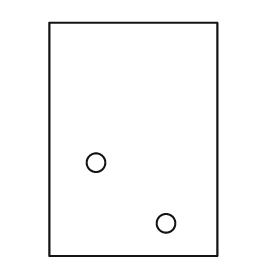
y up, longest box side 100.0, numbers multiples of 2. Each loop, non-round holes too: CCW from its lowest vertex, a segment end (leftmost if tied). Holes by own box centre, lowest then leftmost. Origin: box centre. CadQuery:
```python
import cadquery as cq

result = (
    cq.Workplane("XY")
    .moveTo(-36.0, -50.0)
    .lineTo(36.0, -50.0)
    .lineTo(36.0, 50.0)
    .lineTo(-36.0, 50.0)
    .close()
    .moveTo(14.0, -36.0)
    .circle(4.0)
    .moveTo(-16.0, -10.0)
    .circle(4.0)
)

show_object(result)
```